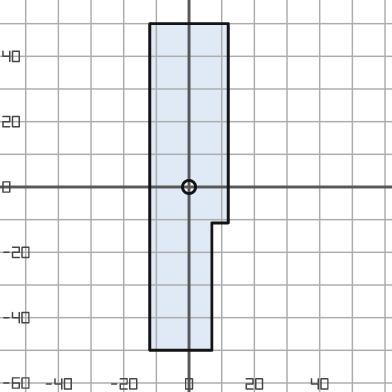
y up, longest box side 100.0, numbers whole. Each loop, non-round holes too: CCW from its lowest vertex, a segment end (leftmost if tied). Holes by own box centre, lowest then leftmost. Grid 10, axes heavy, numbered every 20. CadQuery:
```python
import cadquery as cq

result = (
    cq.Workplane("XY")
    .moveTo(-12.0, -50.0)
    .lineTo(7.0, -50.0)
    .lineTo(7.0, -11.0)
    .lineTo(12.0, -11.0)
    .lineTo(12.0, 50.0)
    .lineTo(-12.0, 50.0)
    .close()
    .moveTo(0.0, 0.0)
    .circle(2.0)
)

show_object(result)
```